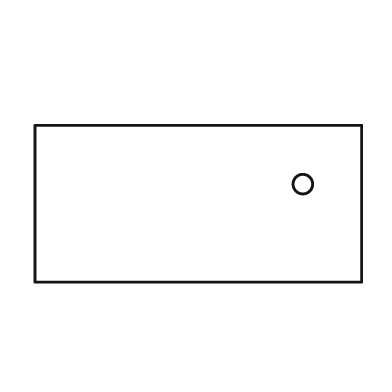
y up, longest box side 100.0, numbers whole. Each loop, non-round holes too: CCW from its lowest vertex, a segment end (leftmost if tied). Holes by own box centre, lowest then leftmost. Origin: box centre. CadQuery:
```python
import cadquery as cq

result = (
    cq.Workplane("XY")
    .moveTo(-50.0, -24.0)
    .lineTo(50.0, -24.0)
    .lineTo(50.0, 24.0)
    .lineTo(-50.0, 24.0)
    .close()
    .moveTo(32.0, 6.0)
    .circle(3.0)
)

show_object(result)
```